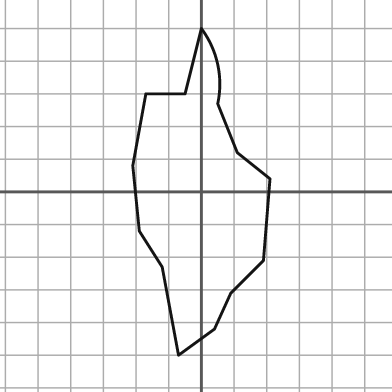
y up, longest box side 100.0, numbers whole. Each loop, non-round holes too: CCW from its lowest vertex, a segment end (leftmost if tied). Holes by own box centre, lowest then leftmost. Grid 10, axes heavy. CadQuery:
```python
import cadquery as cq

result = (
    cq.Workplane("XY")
    .moveTo(-7.0, -50.0)
    .lineTo(4.0, -42.0)
    .lineTo(9.0, -31.0)
    .lineTo(19.0, -21.0)
    .lineTo(21.0, 4.0)
    .lineTo(11.0, 12.0)
    .lineTo(5.0, 27.0)
    .threePointArc((5.0, 39.0), (0.0, 50.0))
    .lineTo(-5.0, 30.0)
    .lineTo(-17.0, 30.0)
    .lineTo(-21.0, 8.0)
    .lineTo(-19.0, -12.0)
    .lineTo(-12.0, -23.0)
    .close()
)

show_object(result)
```